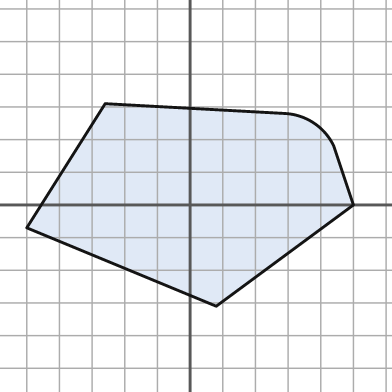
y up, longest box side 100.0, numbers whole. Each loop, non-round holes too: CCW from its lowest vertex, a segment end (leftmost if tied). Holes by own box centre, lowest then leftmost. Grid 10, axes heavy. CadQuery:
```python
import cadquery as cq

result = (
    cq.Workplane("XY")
    .moveTo(8.0, -31.0)
    .lineTo(50.0, 0.0)
    .lineTo(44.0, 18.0)
    .threePointArc((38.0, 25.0), (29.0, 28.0))
    .lineTo(-26.0, 31.0)
    .lineTo(-50.0, -7.0)
    .close()
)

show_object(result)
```